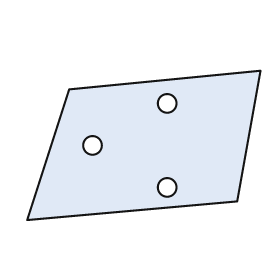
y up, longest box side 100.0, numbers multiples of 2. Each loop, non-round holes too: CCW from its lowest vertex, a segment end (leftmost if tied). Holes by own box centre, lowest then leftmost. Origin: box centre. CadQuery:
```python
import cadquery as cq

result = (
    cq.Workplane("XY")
    .moveTo(-50.0, -32.0)
    .lineTo(40.0, -24.0)
    .lineTo(50.0, 32.0)
    .lineTo(-32.0, 24.0)
    .close()
    .moveTo(10.0, -18.0)
    .circle(4.0)
    .moveTo(-22.0, 0.0)
    .circle(4.0)
    .moveTo(10.0, 18.0)
    .circle(4.0)
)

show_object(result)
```